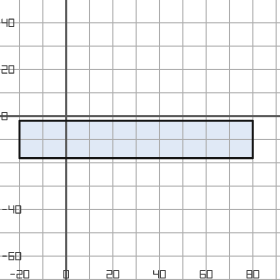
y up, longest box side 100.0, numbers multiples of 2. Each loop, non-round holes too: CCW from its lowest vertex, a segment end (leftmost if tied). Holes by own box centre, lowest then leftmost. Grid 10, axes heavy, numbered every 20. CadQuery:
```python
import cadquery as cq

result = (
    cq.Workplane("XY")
    .moveTo(-20.0, -18.0)
    .lineTo(80.0, -18.0)
    .lineTo(80.0, -2.0)
    .lineTo(-20.0, -2.0)
    .close()
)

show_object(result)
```